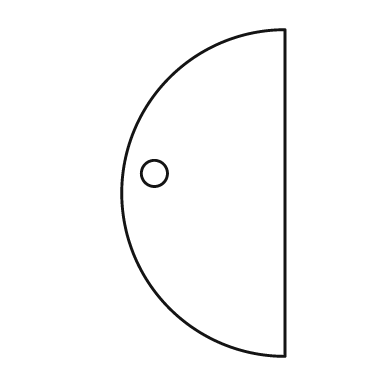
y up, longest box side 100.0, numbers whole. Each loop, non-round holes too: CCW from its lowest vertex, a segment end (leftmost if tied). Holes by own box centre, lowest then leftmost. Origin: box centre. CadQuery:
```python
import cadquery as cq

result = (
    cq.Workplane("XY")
    .moveTo(25.0, -50.0)
    .lineTo(25.0, 50.0)
    .threePointArc((-25.0, 0.0), (25.0, -50.0))
    .close()
    .moveTo(-15.0, 6.0)
    .circle(4.0)
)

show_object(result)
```